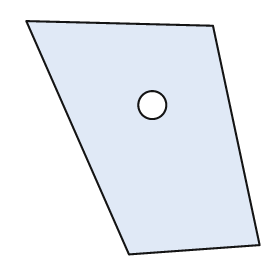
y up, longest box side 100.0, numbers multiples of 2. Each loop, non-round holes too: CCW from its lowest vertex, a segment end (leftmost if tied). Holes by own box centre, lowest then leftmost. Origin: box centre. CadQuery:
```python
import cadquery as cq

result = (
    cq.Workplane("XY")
    .moveTo(-6.0, -50.0)
    .lineTo(50.0, -46.0)
    .lineTo(30.0, 48.0)
    .lineTo(-50.0, 50.0)
    .close()
    .moveTo(4.0, 14.0)
    .circle(6.0)
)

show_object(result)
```